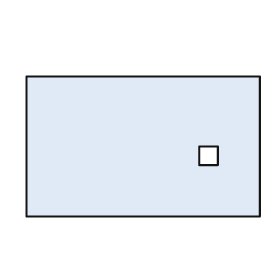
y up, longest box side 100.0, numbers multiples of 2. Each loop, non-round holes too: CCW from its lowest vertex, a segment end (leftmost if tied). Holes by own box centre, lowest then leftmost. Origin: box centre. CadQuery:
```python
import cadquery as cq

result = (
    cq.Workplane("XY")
    .moveTo(-50.0, -30.0)
    .lineTo(50.0, -30.0)
    .lineTo(50.0, 30.0)
    .lineTo(-50.0, 30.0)
    .close()
    .moveTo(24.0, -8.0)
    .lineTo(32.0, -8.0)
    .lineTo(32.0, 0.0)
    .lineTo(24.0, 0.0)
    .close()
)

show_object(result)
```